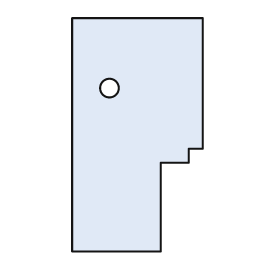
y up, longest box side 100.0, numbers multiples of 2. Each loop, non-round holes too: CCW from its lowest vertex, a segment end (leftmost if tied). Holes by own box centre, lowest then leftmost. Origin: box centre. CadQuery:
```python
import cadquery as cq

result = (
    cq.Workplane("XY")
    .moveTo(-28.0, -50.0)
    .lineTo(10.0, -50.0)
    .lineTo(10.0, -12.0)
    .lineTo(22.0, -12.0)
    .lineTo(22.0, -6.0)
    .lineTo(28.0, -6.0)
    .lineTo(28.0, 50.0)
    .lineTo(-28.0, 50.0)
    .close()
    .moveTo(-12.0, 20.0)
    .circle(4.0)
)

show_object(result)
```